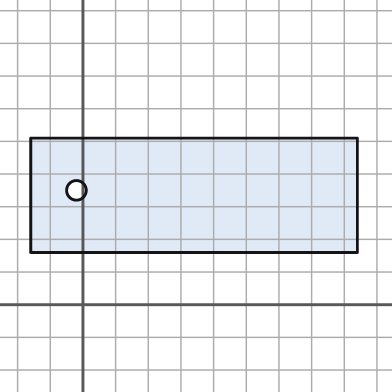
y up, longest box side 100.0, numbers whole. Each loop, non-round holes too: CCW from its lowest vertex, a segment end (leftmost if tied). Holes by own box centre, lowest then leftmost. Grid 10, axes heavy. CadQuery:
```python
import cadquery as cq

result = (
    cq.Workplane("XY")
    .moveTo(-16.0, 16.0)
    .lineTo(84.0, 16.0)
    .lineTo(84.0, 51.0)
    .lineTo(-16.0, 51.0)
    .close()
    .moveTo(-2.0, 35.0)
    .circle(3.0)
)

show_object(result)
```